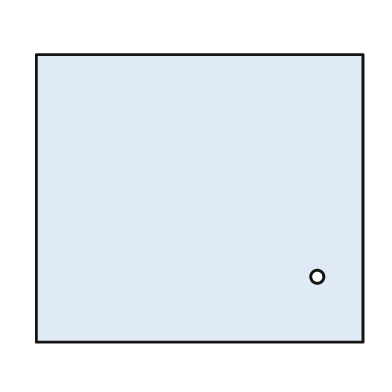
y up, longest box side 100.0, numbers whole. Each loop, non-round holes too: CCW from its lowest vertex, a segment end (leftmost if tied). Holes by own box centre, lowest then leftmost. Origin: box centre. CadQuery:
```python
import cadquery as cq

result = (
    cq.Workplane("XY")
    .moveTo(-50.0, -44.0)
    .lineTo(50.0, -44.0)
    .lineTo(50.0, 44.0)
    .lineTo(-50.0, 44.0)
    .close()
    .moveTo(36.0, -24.0)
    .circle(2.0)
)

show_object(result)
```